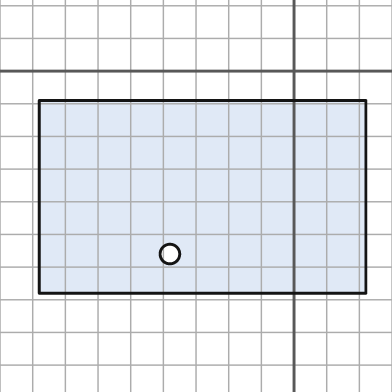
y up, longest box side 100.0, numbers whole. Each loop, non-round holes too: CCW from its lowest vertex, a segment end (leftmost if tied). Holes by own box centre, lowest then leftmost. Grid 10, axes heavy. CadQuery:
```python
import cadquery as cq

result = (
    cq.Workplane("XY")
    .moveTo(-78.0, -68.0)
    .lineTo(22.0, -68.0)
    .lineTo(22.0, -9.0)
    .lineTo(-78.0, -9.0)
    .close()
    .moveTo(-38.0, -56.0)
    .circle(3.0)
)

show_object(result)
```